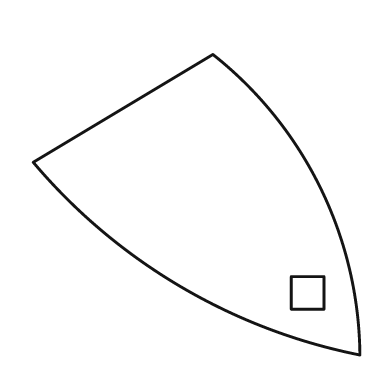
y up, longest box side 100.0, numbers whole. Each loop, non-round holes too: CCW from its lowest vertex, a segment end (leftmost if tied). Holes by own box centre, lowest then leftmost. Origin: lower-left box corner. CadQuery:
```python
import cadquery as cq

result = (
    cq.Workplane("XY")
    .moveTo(100.0, 0.0)
    .threePointArc((88.0, 51.0), (55.0, 92.0))
    .lineTo(0.0, 59.0)
    .threePointArc((45.0, 21.0), (100.0, 0.0))
    .close()
    .moveTo(79.0, 14.0)
    .lineTo(89.0, 14.0)
    .lineTo(89.0, 24.0)
    .lineTo(79.0, 24.0)
    .close()
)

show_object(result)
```